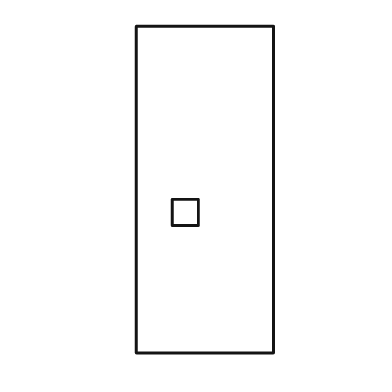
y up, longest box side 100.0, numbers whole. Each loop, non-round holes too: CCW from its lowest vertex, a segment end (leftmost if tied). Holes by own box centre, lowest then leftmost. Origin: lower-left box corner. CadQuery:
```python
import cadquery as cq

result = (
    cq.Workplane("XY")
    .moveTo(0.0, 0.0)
    .lineTo(42.0, 0.0)
    .lineTo(42.0, 100.0)
    .lineTo(0.0, 100.0)
    .close()
    .moveTo(11.0, 39.0)
    .lineTo(19.0, 39.0)
    .lineTo(19.0, 47.0)
    .lineTo(11.0, 47.0)
    .close()
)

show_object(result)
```